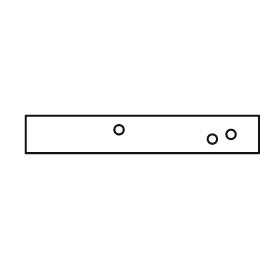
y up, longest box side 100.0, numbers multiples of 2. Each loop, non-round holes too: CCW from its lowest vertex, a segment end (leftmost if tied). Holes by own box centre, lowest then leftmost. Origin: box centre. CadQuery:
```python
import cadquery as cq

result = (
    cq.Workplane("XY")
    .moveTo(-50.0, -8.0)
    .lineTo(50.0, -8.0)
    .lineTo(50.0, 8.0)
    .lineTo(-50.0, 8.0)
    .close()
    .moveTo(30.0, -2.0)
    .circle(2.0)
    .moveTo(38.0, 0.0)
    .circle(2.0)
    .moveTo(-10.0, 2.0)
    .circle(2.0)
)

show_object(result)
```